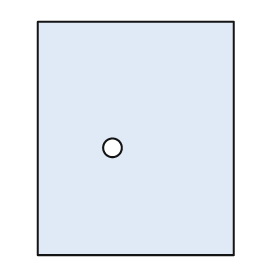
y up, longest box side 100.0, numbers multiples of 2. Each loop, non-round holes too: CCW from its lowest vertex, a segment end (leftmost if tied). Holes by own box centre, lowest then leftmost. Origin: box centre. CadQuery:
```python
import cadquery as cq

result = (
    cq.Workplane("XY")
    .moveTo(-42.0, -50.0)
    .lineTo(42.0, -50.0)
    .lineTo(42.0, 50.0)
    .lineTo(-42.0, 50.0)
    .close()
    .moveTo(-10.0, -4.0)
    .circle(4.0)
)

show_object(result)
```